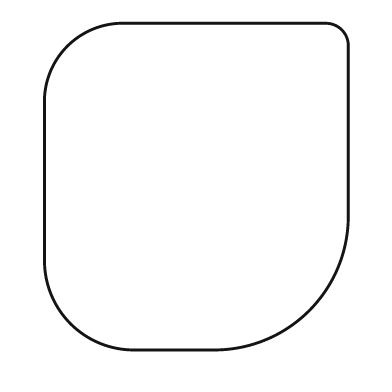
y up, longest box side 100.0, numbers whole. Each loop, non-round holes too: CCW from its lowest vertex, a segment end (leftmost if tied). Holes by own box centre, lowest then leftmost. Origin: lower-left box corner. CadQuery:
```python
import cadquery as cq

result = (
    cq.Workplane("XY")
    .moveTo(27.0, 0.0)
    .lineTo(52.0, 0.0)
    .threePointArc((81.0, 12.0), (93.0, 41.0))
    .lineTo(93.0, 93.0)
    .threePointArc((91.0, 98.0), (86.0, 100.0))
    .lineTo(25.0, 100.0)
    .threePointArc((7.0, 93.0), (0.0, 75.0))
    .lineTo(0.0, 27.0)
    .threePointArc((8.0, 8.0), (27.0, 0.0))
    .close()
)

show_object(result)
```